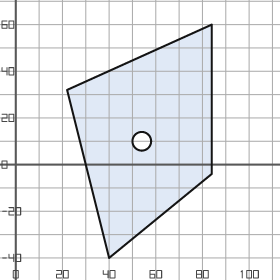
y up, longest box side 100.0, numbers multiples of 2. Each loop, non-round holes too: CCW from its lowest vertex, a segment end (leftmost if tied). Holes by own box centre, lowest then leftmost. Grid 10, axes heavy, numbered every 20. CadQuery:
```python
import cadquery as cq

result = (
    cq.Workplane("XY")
    .moveTo(40.0, -40.0)
    .lineTo(84.0, -4.0)
    .lineTo(84.0, 60.0)
    .lineTo(22.0, 32.0)
    .close()
    .moveTo(54.0, 10.0)
    .circle(4.0)
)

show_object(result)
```